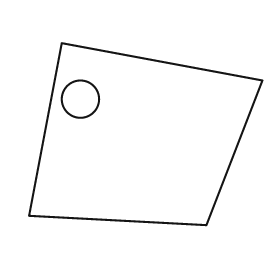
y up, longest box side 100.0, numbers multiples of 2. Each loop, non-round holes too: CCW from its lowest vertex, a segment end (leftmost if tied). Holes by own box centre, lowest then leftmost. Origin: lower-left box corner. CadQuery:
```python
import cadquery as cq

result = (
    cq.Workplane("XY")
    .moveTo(76.0, 0.0)
    .lineTo(100.0, 62.0)
    .lineTo(14.0, 78.0)
    .lineTo(0.0, 4.0)
    .close()
    .moveTo(22.0, 54.0)
    .circle(8.0)
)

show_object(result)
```